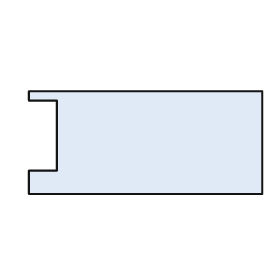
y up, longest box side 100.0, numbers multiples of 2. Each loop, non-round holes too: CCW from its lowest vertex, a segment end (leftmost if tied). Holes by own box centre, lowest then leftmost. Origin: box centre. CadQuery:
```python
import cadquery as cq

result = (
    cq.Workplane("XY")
    .moveTo(-50.0, -22.0)
    .lineTo(50.0, -22.0)
    .lineTo(50.0, 22.0)
    .lineTo(-50.0, 22.0)
    .lineTo(-50.0, 18.0)
    .lineTo(-38.0, 18.0)
    .lineTo(-38.0, -12.0)
    .lineTo(-50.0, -12.0)
    .close()
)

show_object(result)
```